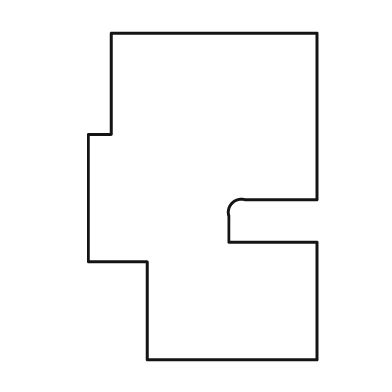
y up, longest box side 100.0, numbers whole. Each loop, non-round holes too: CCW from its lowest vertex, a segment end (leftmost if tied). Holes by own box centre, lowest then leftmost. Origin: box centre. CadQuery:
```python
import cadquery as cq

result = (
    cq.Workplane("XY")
    .moveTo(-17.0, -50.0)
    .lineTo(35.0, -50.0)
    .lineTo(35.0, -14.0)
    .lineTo(8.0, -14.0)
    .lineTo(8.0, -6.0)
    .threePointArc((9.0, -2.0), (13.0, -1.0))
    .lineTo(35.0, -1.0)
    .lineTo(35.0, 50.0)
    .lineTo(-28.0, 50.0)
    .lineTo(-28.0, 19.0)
    .lineTo(-35.0, 19.0)
    .lineTo(-35.0, -20.0)
    .lineTo(-17.0, -20.0)
    .close()
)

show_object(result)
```